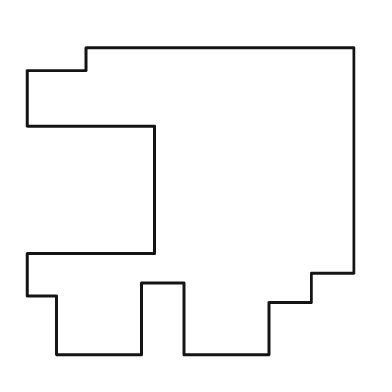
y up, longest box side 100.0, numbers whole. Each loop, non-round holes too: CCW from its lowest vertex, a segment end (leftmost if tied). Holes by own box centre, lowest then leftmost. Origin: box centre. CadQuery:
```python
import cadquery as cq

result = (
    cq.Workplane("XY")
    .moveTo(-41.0, -47.0)
    .lineTo(-15.0, -47.0)
    .lineTo(-15.0, -25.0)
    .lineTo(-2.0, -25.0)
    .lineTo(-2.0, -47.0)
    .lineTo(24.0, -47.0)
    .lineTo(24.0, -31.0)
    .lineTo(37.0, -31.0)
    .lineTo(37.0, -22.0)
    .lineTo(50.0, -22.0)
    .lineTo(50.0, 47.0)
    .lineTo(-32.0, 47.0)
    .lineTo(-32.0, 40.0)
    .lineTo(-50.0, 40.0)
    .lineTo(-50.0, 23.0)
    .lineTo(-11.0, 23.0)
    .lineTo(-11.0, -16.0)
    .lineTo(-50.0, -16.0)
    .lineTo(-50.0, -29.0)
    .lineTo(-41.0, -29.0)
    .close()
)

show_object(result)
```